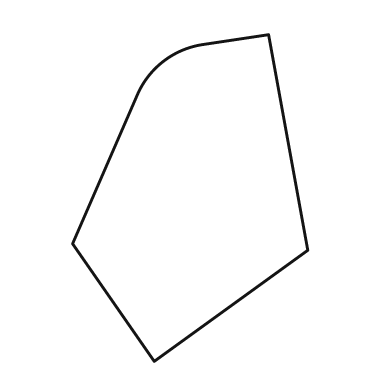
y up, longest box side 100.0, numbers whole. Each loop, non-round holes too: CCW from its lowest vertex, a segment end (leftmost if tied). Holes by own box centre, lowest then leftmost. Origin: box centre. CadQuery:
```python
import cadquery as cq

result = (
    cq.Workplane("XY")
    .moveTo(-11.0, -50.0)
    .lineTo(36.0, -16.0)
    .lineTo(24.0, 50.0)
    .lineTo(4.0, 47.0)
    .threePointArc((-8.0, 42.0), (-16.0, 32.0))
    .lineTo(-36.0, -14.0)
    .close()
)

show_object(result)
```